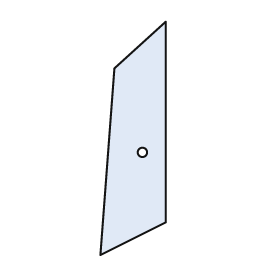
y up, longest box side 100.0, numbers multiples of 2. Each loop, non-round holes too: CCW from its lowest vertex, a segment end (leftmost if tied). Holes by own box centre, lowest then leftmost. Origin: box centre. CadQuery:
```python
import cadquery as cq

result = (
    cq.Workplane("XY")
    .moveTo(-14.0, -50.0)
    .lineTo(14.0, -36.0)
    .lineTo(14.0, 50.0)
    .lineTo(-8.0, 30.0)
    .close()
    .moveTo(4.0, -6.0)
    .circle(2.0)
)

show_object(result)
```